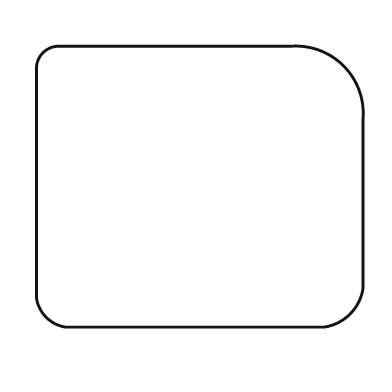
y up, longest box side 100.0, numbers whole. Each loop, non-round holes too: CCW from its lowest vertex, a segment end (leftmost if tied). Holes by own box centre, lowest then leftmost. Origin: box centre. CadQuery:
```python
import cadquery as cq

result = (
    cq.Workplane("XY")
    .moveTo(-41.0, -43.0)
    .lineTo(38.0, -43.0)
    .threePointArc((46.0, -39.0), (50.0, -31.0))
    .lineTo(50.0, 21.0)
    .threePointArc((44.0, 37.0), (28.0, 43.0))
    .lineTo(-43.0, 43.0)
    .threePointArc((-48.0, 41.0), (-50.0, 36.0))
    .lineTo(-50.0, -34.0)
    .threePointArc((-47.0, -40.0), (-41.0, -43.0))
    .close()
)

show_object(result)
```